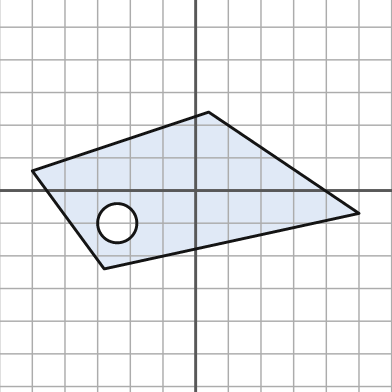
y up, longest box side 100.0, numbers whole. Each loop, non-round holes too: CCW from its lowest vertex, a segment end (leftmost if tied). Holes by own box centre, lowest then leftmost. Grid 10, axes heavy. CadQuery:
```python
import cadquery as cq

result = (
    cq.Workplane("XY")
    .moveTo(-28.0, -24.0)
    .lineTo(50.0, -7.0)
    .lineTo(4.0, 24.0)
    .lineTo(-50.0, 6.0)
    .close()
    .moveTo(-24.0, -10.0)
    .circle(6.0)
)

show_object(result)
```